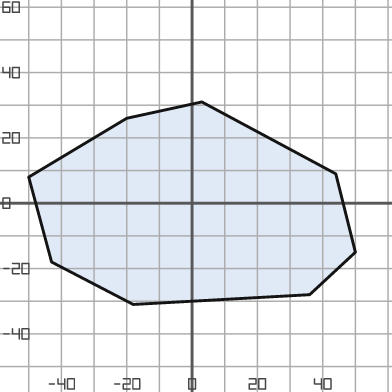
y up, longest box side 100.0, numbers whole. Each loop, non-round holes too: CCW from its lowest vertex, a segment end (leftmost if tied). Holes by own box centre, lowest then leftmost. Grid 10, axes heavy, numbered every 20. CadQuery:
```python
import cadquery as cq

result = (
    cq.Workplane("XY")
    .moveTo(-18.0, -31.0)
    .lineTo(36.0, -28.0)
    .lineTo(50.0, -15.0)
    .lineTo(44.0, 9.0)
    .lineTo(3.0, 31.0)
    .lineTo(-20.0, 26.0)
    .lineTo(-50.0, 8.0)
    .lineTo(-43.0, -18.0)
    .close()
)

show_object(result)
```